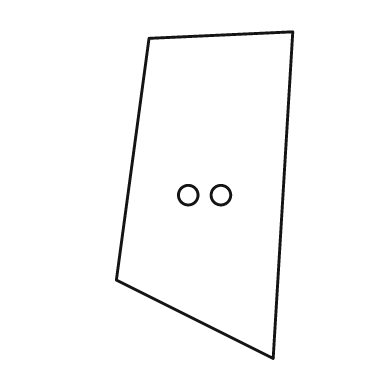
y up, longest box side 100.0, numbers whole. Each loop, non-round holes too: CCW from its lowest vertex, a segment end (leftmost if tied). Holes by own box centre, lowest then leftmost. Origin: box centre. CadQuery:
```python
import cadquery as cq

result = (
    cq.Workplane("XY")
    .moveTo(21.0, -50.0)
    .lineTo(27.0, 50.0)
    .lineTo(-17.0, 48.0)
    .lineTo(-27.0, -26.0)
    .close()
    .moveTo(-5.0, 0.0)
    .circle(3.0)
    .moveTo(5.0, 0.0)
    .circle(3.0)
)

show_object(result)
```